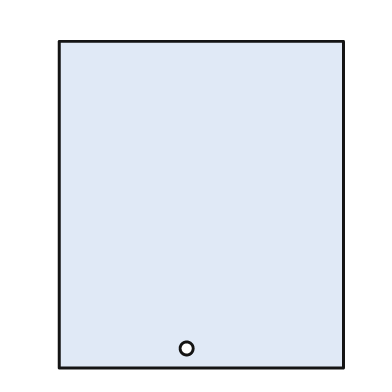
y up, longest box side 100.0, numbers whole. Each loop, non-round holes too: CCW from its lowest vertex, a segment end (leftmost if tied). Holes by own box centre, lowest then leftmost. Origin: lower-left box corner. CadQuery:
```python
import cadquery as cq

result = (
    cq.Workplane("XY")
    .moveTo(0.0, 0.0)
    .lineTo(87.0, 0.0)
    .lineTo(87.0, 100.0)
    .lineTo(0.0, 100.0)
    .close()
    .moveTo(39.0, 6.0)
    .circle(2.0)
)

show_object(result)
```